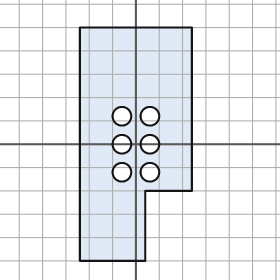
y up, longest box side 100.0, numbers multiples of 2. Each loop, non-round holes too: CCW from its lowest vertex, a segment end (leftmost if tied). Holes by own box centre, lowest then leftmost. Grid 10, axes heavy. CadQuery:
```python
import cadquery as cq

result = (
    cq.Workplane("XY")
    .moveTo(-24.0, -50.0)
    .lineTo(4.0, -50.0)
    .lineTo(4.0, -20.0)
    .lineTo(24.0, -20.0)
    .lineTo(24.0, 50.0)
    .lineTo(-24.0, 50.0)
    .close()
    .moveTo(-6.0, -12.0)
    .circle(4.0)
    .moveTo(6.0, -12.0)
    .circle(4.0)
    .moveTo(-6.0, 0.0)
    .circle(4.0)
    .moveTo(6.0, 0.0)
    .circle(4.0)
    .moveTo(-6.0, 12.0)
    .circle(4.0)
    .moveTo(6.0, 12.0)
    .circle(4.0)
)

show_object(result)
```